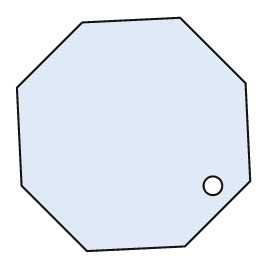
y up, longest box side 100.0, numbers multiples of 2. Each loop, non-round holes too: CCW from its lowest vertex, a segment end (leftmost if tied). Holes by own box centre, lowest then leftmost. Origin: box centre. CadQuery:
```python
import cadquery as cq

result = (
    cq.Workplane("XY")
    .moveTo(-20.0, -50.0)
    .lineTo(22.0, -48.0)
    .lineTo(50.0, -20.0)
    .lineTo(48.0, 22.0)
    .lineTo(20.0, 50.0)
    .lineTo(-22.0, 48.0)
    .lineTo(-50.0, 20.0)
    .lineTo(-48.0, -22.0)
    .close()
    .moveTo(34.0, -22.0)
    .circle(4.0)
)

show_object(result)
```